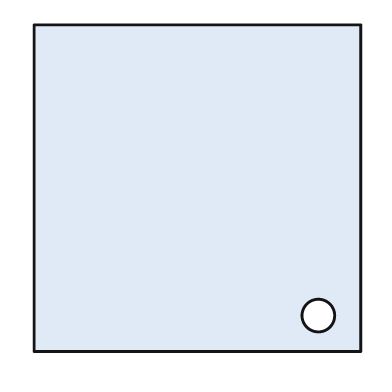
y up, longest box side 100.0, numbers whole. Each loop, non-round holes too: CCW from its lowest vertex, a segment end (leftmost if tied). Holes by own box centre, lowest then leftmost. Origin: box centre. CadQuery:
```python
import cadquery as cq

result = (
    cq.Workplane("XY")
    .moveTo(-50.0, -50.0)
    .lineTo(50.0, -50.0)
    .lineTo(50.0, 50.0)
    .lineTo(-50.0, 50.0)
    .close()
    .moveTo(37.0, -39.0)
    .circle(5.0)
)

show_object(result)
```